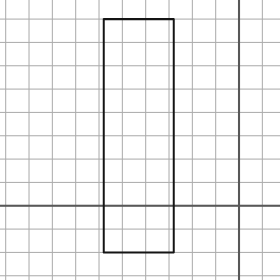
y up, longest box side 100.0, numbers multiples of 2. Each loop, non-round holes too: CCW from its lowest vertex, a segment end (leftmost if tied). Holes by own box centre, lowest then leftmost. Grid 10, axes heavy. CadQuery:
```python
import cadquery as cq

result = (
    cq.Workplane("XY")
    .moveTo(-58.0, -20.0)
    .lineTo(-28.0, -20.0)
    .lineTo(-28.0, 80.0)
    .lineTo(-58.0, 80.0)
    .close()
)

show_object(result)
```